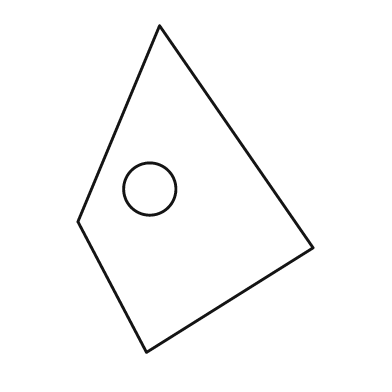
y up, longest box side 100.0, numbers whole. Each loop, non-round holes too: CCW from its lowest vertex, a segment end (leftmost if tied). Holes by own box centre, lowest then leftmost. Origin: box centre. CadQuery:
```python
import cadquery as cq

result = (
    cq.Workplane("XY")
    .moveTo(-15.0, -50.0)
    .lineTo(36.0, -18.0)
    .lineTo(-11.0, 50.0)
    .lineTo(-36.0, -10.0)
    .close()
    .moveTo(-14.0, 0.0)
    .circle(8.0)
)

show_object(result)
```